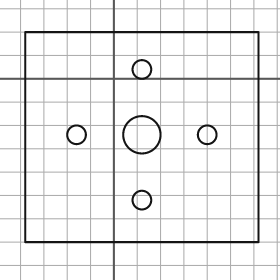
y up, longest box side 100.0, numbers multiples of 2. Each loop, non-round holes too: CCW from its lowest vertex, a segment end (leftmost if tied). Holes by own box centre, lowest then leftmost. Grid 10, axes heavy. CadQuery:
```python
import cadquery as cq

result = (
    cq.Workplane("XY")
    .moveTo(-38.0, -70.0)
    .lineTo(62.0, -70.0)
    .lineTo(62.0, 20.0)
    .lineTo(-38.0, 20.0)
    .close()
    .moveTo(12.0, -52.0)
    .circle(4.0)
    .moveTo(-16.0, -24.0)
    .circle(4.0)
    .moveTo(12.0, -24.0)
    .circle(8.0)
    .moveTo(40.0, -24.0)
    .circle(4.0)
    .moveTo(12.0, 4.0)
    .circle(4.0)
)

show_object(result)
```